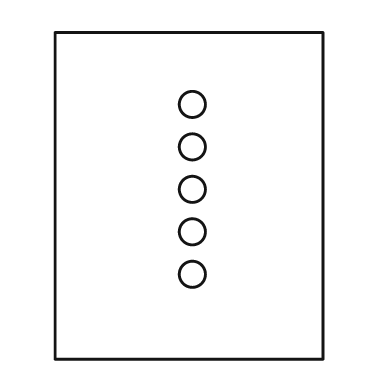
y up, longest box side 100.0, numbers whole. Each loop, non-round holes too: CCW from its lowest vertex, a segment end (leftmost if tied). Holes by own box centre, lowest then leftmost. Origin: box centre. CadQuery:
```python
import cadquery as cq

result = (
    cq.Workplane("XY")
    .moveTo(-41.0, -50.0)
    .lineTo(41.0, -50.0)
    .lineTo(41.0, 50.0)
    .lineTo(-41.0, 50.0)
    .close()
    .moveTo(1.0, -24.0)
    .circle(4.0)
    .moveTo(1.0, -11.0)
    .circle(4.0)
    .moveTo(1.0, 2.0)
    .circle(4.0)
    .moveTo(1.0, 15.0)
    .circle(4.0)
    .moveTo(1.0, 28.0)
    .circle(4.0)
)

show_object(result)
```